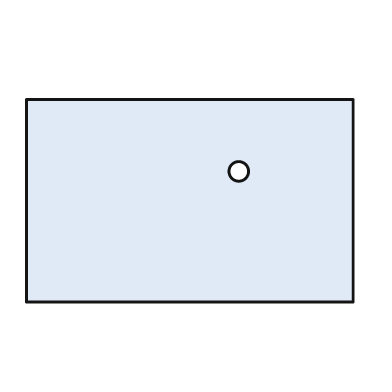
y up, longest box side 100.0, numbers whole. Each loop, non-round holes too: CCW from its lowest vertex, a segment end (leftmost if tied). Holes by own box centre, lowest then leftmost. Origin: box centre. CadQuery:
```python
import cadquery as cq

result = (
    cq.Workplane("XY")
    .moveTo(-50.0, -31.0)
    .lineTo(50.0, -31.0)
    .lineTo(50.0, 31.0)
    .lineTo(-50.0, 31.0)
    .close()
    .moveTo(15.0, 9.0)
    .circle(3.0)
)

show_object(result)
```